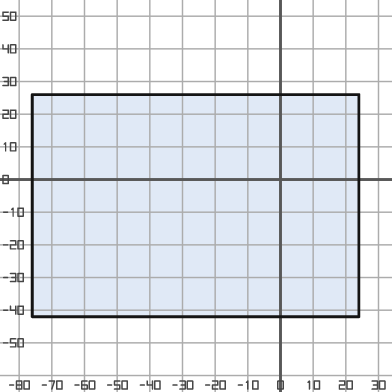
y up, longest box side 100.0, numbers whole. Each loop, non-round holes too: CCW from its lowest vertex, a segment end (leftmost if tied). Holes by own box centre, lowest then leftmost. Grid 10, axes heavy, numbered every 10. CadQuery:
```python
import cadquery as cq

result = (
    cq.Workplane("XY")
    .moveTo(-76.0, -42.0)
    .lineTo(24.0, -42.0)
    .lineTo(24.0, 26.0)
    .lineTo(-76.0, 26.0)
    .close()
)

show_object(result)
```